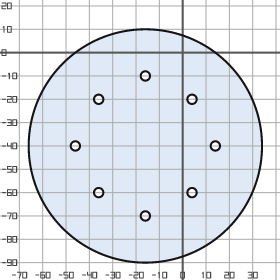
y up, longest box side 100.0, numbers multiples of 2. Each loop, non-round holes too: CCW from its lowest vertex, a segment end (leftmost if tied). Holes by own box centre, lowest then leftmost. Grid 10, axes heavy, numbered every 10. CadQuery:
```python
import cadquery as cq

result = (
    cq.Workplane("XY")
    .moveTo(-16.0, -40.0)
    .circle(50.0)
    .moveTo(-16.0, -70.0)
    .circle(2.0)
    .moveTo(-36.0, -60.0)
    .circle(2.0)
    .moveTo(4.0, -60.0)
    .circle(2.0)
    .moveTo(-46.0, -40.0)
    .circle(2.0)
    .moveTo(14.0, -40.0)
    .circle(2.0)
    .moveTo(-36.0, -20.0)
    .circle(2.0)
    .moveTo(4.0, -20.0)
    .circle(2.0)
    .moveTo(-16.0, -10.0)
    .circle(2.0)
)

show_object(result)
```